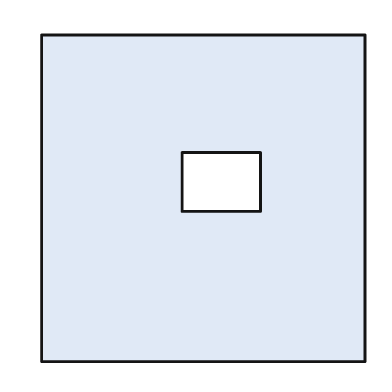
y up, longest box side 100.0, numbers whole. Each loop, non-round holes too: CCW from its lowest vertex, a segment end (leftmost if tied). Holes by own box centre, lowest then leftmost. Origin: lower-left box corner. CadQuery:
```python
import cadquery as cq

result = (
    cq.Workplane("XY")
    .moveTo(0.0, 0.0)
    .lineTo(99.0, 0.0)
    .lineTo(99.0, 100.0)
    .lineTo(0.0, 100.0)
    .close()
    .moveTo(43.0, 46.0)
    .lineTo(67.0, 46.0)
    .lineTo(67.0, 64.0)
    .lineTo(43.0, 64.0)
    .close()
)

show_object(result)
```